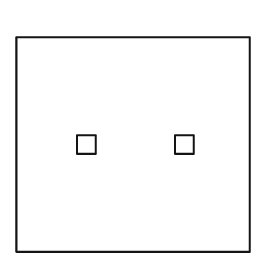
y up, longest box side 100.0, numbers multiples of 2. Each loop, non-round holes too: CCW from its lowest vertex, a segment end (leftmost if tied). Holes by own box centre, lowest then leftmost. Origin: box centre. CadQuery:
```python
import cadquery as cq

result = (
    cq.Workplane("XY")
    .moveTo(-50.0, -46.0)
    .lineTo(50.0, -46.0)
    .lineTo(50.0, 46.0)
    .lineTo(-50.0, 46.0)
    .close()
    .moveTo(-24.0, -4.0)
    .lineTo(-16.0, -4.0)
    .lineTo(-16.0, 4.0)
    .lineTo(-24.0, 4.0)
    .close()
    .moveTo(18.0, -4.0)
    .lineTo(26.0, -4.0)
    .lineTo(26.0, 4.0)
    .lineTo(18.0, 4.0)
    .close()
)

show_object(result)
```